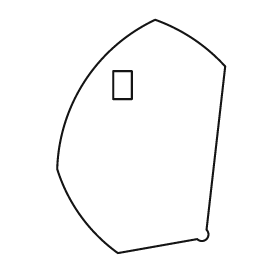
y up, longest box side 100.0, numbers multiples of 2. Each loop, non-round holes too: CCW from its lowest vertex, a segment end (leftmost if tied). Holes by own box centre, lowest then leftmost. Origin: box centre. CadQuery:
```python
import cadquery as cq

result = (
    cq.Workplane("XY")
    .moveTo(-10.0, -50.0)
    .lineTo(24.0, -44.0)
    .threePointArc((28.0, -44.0), (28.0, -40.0))
    .lineTo(36.0, 30.0)
    .threePointArc((22.0, 42.0), (6.0, 50.0))
    .threePointArc((-24.0, 24.0), (-36.0, -14.0))
    .threePointArc((-26.0, -34.0), (-10.0, -50.0))
    .close()
    .moveTo(-12.0, 16.0)
    .lineTo(-4.0, 16.0)
    .lineTo(-4.0, 28.0)
    .lineTo(-12.0, 28.0)
    .close()
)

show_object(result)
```